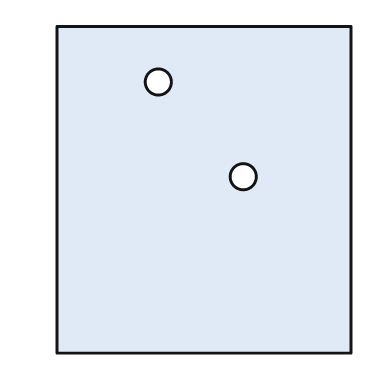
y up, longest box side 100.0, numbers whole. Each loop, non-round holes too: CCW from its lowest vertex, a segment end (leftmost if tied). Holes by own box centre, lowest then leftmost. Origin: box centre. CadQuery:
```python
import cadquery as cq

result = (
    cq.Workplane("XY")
    .moveTo(-45.0, -50.0)
    .lineTo(45.0, -50.0)
    .lineTo(45.0, 50.0)
    .lineTo(-45.0, 50.0)
    .close()
    .moveTo(12.0, 4.0)
    .circle(4.0)
    .moveTo(-14.0, 33.0)
    .circle(4.0)
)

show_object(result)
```